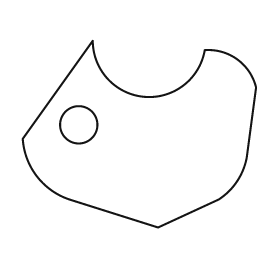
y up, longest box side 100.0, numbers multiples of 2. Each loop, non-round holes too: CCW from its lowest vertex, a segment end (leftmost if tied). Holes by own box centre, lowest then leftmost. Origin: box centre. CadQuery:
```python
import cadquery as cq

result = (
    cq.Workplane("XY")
    .moveTo(8.0, -40.0)
    .lineTo(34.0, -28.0)
    .threePointArc((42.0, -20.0), (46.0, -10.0))
    .lineTo(50.0, 20.0)
    .threePointArc((42.0, 32.0), (28.0, 36.0))
    .threePointArc((2.0, 16.0), (-20.0, 40.0))
    .lineTo(-50.0, -2.0)
    .threePointArc((-44.0, -18.0), (-30.0, -28.0))
    .close()
    .moveTo(-26.0, 4.0)
    .circle(8.0)
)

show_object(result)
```